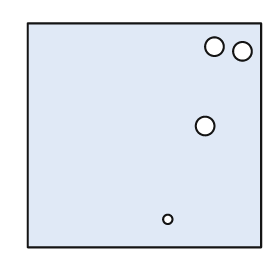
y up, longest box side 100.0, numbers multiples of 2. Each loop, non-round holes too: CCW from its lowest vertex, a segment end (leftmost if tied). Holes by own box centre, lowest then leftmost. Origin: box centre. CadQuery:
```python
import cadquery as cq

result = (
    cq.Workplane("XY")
    .moveTo(-50.0, -48.0)
    .lineTo(50.0, -48.0)
    .lineTo(50.0, 48.0)
    .lineTo(-50.0, 48.0)
    .close()
    .moveTo(10.0, -36.0)
    .circle(2.0)
    .moveTo(26.0, 4.0)
    .circle(4.0)
    .moveTo(42.0, 36.0)
    .circle(4.0)
    .moveTo(30.0, 38.0)
    .circle(4.0)
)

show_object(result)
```